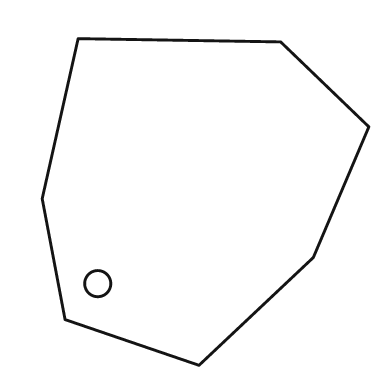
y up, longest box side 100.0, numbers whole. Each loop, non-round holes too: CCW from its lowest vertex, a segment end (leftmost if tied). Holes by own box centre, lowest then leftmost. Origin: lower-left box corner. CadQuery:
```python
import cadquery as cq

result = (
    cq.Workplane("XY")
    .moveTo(48.0, 0.0)
    .lineTo(83.0, 33.0)
    .lineTo(100.0, 73.0)
    .lineTo(73.0, 99.0)
    .lineTo(11.0, 100.0)
    .lineTo(0.0, 51.0)
    .lineTo(7.0, 14.0)
    .close()
    .moveTo(17.0, 25.0)
    .circle(4.0)
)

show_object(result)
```